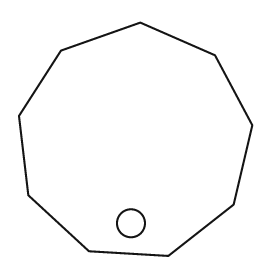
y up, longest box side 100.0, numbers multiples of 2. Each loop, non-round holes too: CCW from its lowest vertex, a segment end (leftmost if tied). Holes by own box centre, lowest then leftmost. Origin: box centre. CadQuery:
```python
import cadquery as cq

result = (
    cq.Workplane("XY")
    .moveTo(14.0, -50.0)
    .lineTo(42.0, -28.0)
    .lineTo(50.0, 6.0)
    .lineTo(34.0, 36.0)
    .lineTo(2.0, 50.0)
    .lineTo(-32.0, 38.0)
    .lineTo(-50.0, 10.0)
    .lineTo(-46.0, -24.0)
    .lineTo(-20.0, -48.0)
    .close()
    .moveTo(-2.0, -36.0)
    .circle(6.0)
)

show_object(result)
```